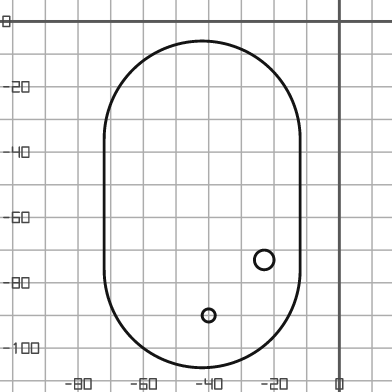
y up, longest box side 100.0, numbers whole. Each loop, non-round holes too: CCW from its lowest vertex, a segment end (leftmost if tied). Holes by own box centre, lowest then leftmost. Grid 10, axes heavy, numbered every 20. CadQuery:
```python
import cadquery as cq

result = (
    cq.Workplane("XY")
    .moveTo(-72.0, -76.0)
    .threePointArc((-42.0, -106.0), (-12.0, -76.0))
    .lineTo(-12.0, -36.0)
    .threePointArc((-42.0, -6.0), (-72.0, -36.0))
    .close()
    .moveTo(-40.0, -90.0)
    .circle(2.0)
    .moveTo(-23.0, -73.0)
    .circle(3.0)
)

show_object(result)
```